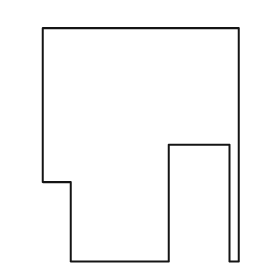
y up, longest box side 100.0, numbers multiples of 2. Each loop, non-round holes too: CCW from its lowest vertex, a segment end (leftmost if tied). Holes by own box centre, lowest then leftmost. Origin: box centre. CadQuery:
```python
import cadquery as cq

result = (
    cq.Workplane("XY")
    .moveTo(-30.0, -50.0)
    .lineTo(12.0, -50.0)
    .lineTo(12.0, 0.0)
    .lineTo(38.0, 0.0)
    .lineTo(38.0, -50.0)
    .lineTo(42.0, -50.0)
    .lineTo(42.0, 50.0)
    .lineTo(-42.0, 50.0)
    .lineTo(-42.0, -16.0)
    .lineTo(-30.0, -16.0)
    .close()
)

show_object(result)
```